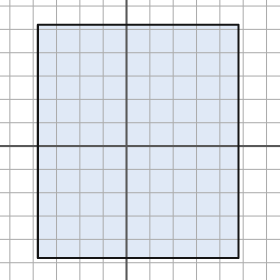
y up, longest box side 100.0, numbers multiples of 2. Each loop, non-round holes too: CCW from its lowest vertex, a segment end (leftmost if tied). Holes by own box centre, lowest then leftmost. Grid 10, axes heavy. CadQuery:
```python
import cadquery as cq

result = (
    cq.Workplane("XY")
    .moveTo(-38.0, -48.0)
    .lineTo(48.0, -48.0)
    .lineTo(48.0, 52.0)
    .lineTo(-38.0, 52.0)
    .close()
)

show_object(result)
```